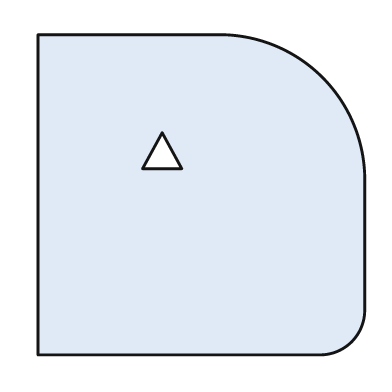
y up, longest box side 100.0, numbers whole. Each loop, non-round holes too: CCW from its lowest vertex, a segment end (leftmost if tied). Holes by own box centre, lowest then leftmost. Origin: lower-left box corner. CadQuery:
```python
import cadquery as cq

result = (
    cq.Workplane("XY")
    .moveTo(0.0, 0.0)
    .lineTo(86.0, 0.0)
    .threePointArc((96.0, 4.0), (100.0, 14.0))
    .lineTo(100.0, 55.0)
    .threePointArc((87.0, 85.0), (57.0, 98.0))
    .lineTo(0.0, 98.0)
    .close()
    .moveTo(32.0, 57.0)
    .lineTo(44.0, 57.0)
    .lineTo(38.0, 68.0)
    .close()
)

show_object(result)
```